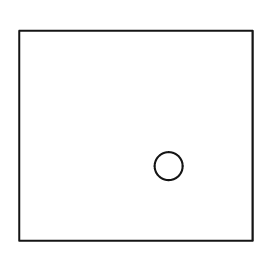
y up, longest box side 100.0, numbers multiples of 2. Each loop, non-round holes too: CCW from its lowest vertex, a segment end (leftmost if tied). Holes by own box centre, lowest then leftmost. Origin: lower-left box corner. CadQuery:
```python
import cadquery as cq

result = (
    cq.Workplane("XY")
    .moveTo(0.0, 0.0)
    .lineTo(100.0, 0.0)
    .lineTo(100.0, 90.0)
    .lineTo(0.0, 90.0)
    .close()
    .moveTo(64.0, 32.0)
    .circle(6.0)
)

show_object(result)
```